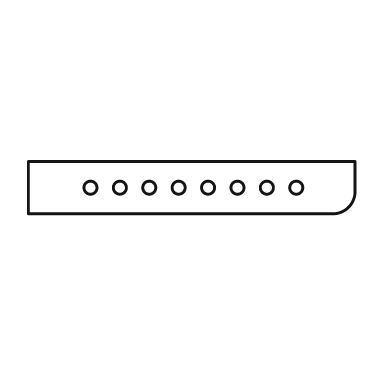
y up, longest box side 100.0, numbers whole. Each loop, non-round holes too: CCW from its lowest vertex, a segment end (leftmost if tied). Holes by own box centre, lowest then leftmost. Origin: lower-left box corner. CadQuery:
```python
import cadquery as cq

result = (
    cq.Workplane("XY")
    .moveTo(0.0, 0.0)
    .lineTo(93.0, 0.0)
    .threePointArc((98.0, 2.0), (100.0, 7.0))
    .lineTo(100.0, 16.0)
    .lineTo(0.0, 16.0)
    .close()
    .moveTo(19.0, 8.0)
    .circle(2.0)
    .moveTo(28.0, 8.0)
    .circle(2.0)
    .moveTo(37.0, 8.0)
    .circle(2.0)
    .moveTo(46.0, 8.0)
    .circle(2.0)
    .moveTo(55.0, 8.0)
    .circle(2.0)
    .moveTo(64.0, 8.0)
    .circle(2.0)
    .moveTo(73.0, 8.0)
    .circle(2.0)
    .moveTo(82.0, 8.0)
    .circle(2.0)
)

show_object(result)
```